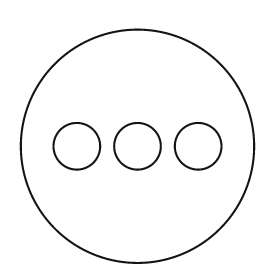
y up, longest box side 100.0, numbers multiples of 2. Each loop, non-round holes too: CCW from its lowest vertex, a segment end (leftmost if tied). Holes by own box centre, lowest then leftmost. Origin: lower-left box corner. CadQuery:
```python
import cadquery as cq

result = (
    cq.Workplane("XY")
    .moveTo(50.0, 50.0)
    .circle(50.0)
    .moveTo(24.0, 50.0)
    .circle(10.0)
    .moveTo(50.0, 50.0)
    .circle(10.0)
    .moveTo(76.0, 50.0)
    .circle(10.0)
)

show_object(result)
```